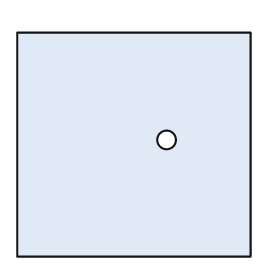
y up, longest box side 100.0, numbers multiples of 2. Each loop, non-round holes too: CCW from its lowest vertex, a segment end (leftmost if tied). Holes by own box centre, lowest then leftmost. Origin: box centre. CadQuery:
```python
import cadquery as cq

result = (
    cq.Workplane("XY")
    .moveTo(-50.0, -48.0)
    .lineTo(50.0, -48.0)
    .lineTo(50.0, 48.0)
    .lineTo(-50.0, 48.0)
    .close()
    .moveTo(14.0, 2.0)
    .circle(4.0)
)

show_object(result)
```